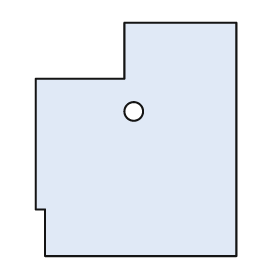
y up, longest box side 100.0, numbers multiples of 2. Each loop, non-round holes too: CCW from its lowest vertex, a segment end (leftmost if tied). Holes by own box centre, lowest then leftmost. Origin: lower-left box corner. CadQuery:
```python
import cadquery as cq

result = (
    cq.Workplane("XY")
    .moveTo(4.0, 0.0)
    .lineTo(86.0, 0.0)
    .lineTo(86.0, 100.0)
    .lineTo(38.0, 100.0)
    .lineTo(38.0, 76.0)
    .lineTo(0.0, 76.0)
    .lineTo(0.0, 20.0)
    .lineTo(4.0, 20.0)
    .close()
    .moveTo(42.0, 62.0)
    .circle(4.0)
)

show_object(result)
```